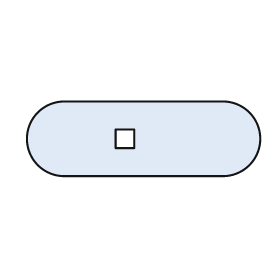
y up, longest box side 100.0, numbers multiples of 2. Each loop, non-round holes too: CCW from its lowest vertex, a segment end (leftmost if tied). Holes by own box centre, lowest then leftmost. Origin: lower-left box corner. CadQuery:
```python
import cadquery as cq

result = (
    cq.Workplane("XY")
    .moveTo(16.0, 0.0)
    .lineTo(84.0, 0.0)
    .threePointArc((100.0, 16.0), (84.0, 32.0))
    .lineTo(16.0, 32.0)
    .threePointArc((0.0, 16.0), (16.0, 0.0))
    .close()
    .moveTo(38.0, 12.0)
    .lineTo(46.0, 12.0)
    .lineTo(46.0, 20.0)
    .lineTo(38.0, 20.0)
    .close()
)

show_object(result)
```